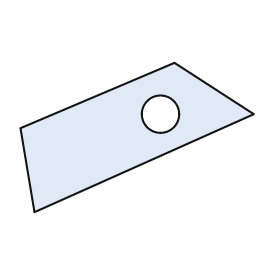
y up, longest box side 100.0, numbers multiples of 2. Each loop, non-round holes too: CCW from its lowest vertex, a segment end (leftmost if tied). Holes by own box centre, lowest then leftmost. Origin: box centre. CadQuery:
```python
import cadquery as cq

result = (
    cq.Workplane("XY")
    .moveTo(-44.0, -32.0)
    .lineTo(50.0, 10.0)
    .lineTo(16.0, 32.0)
    .lineTo(-50.0, 4.0)
    .close()
    .moveTo(10.0, 10.0)
    .circle(8.0)
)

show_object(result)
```